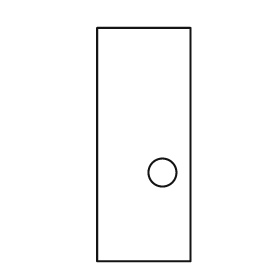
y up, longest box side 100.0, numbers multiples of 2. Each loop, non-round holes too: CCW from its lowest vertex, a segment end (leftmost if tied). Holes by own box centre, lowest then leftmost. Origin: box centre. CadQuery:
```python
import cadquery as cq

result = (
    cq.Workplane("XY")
    .moveTo(-20.0, -50.0)
    .lineTo(20.0, -50.0)
    .lineTo(20.0, 50.0)
    .lineTo(-20.0, 50.0)
    .close()
    .moveTo(8.0, -12.0)
    .circle(6.0)
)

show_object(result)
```